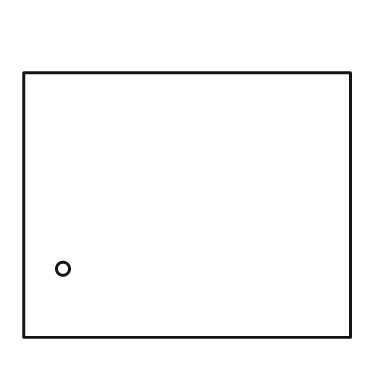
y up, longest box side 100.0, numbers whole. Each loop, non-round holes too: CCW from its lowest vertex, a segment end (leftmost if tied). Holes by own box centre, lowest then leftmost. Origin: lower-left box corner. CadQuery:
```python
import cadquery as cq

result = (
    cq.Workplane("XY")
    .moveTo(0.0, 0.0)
    .lineTo(100.0, 0.0)
    .lineTo(100.0, 81.0)
    .lineTo(0.0, 81.0)
    .close()
    .moveTo(12.0, 21.0)
    .circle(2.0)
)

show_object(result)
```